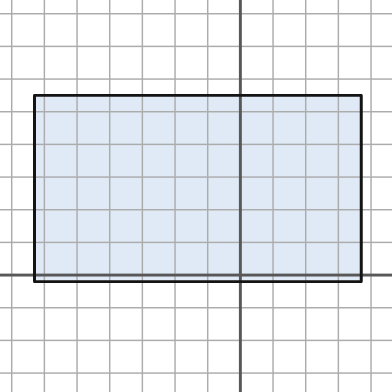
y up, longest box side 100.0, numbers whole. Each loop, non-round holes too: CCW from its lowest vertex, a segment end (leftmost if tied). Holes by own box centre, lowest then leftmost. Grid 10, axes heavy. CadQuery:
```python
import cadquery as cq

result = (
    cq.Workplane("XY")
    .moveTo(-63.0, -2.0)
    .lineTo(37.0, -2.0)
    .lineTo(37.0, 55.0)
    .lineTo(-63.0, 55.0)
    .close()
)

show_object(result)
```